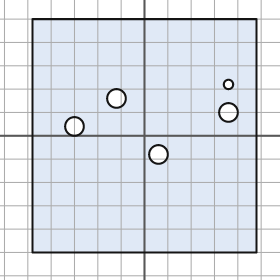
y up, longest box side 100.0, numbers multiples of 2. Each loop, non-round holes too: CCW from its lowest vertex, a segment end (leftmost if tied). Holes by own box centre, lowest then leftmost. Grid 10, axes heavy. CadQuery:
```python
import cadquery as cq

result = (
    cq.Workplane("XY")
    .moveTo(-48.0, -50.0)
    .lineTo(48.0, -50.0)
    .lineTo(48.0, 50.0)
    .lineTo(-48.0, 50.0)
    .close()
    .moveTo(6.0, -8.0)
    .circle(4.0)
    .moveTo(-30.0, 4.0)
    .circle(4.0)
    .moveTo(36.0, 10.0)
    .circle(4.0)
    .moveTo(-12.0, 16.0)
    .circle(4.0)
    .moveTo(36.0, 22.0)
    .circle(2.0)
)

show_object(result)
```